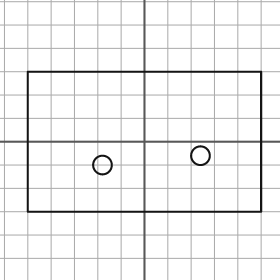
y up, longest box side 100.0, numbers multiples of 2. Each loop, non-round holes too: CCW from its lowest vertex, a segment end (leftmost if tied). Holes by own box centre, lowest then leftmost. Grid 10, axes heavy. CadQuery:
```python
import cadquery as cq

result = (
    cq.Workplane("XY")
    .moveTo(-50.0, -30.0)
    .lineTo(50.0, -30.0)
    .lineTo(50.0, 30.0)
    .lineTo(-50.0, 30.0)
    .close()
    .moveTo(-18.0, -10.0)
    .circle(4.0)
    .moveTo(24.0, -6.0)
    .circle(4.0)
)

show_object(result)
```